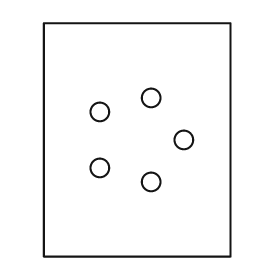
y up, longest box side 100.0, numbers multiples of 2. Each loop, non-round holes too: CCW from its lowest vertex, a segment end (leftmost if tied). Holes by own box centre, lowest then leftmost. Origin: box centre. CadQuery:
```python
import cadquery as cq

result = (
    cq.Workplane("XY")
    .moveTo(-40.0, -50.0)
    .lineTo(40.0, -50.0)
    .lineTo(40.0, 50.0)
    .lineTo(-40.0, 50.0)
    .close()
    .moveTo(6.0, -18.0)
    .circle(4.0)
    .moveTo(-16.0, -12.0)
    .circle(4.0)
    .moveTo(20.0, 0.0)
    .circle(4.0)
    .moveTo(-16.0, 12.0)
    .circle(4.0)
    .moveTo(6.0, 18.0)
    .circle(4.0)
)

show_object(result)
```